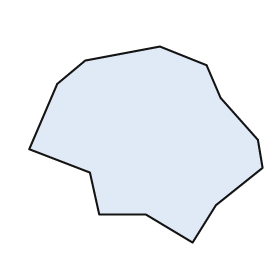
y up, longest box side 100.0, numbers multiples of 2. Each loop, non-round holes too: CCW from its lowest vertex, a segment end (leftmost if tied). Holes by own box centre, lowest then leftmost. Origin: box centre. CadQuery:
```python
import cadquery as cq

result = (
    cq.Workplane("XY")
    .moveTo(20.0, -42.0)
    .lineTo(30.0, -26.0)
    .lineTo(50.0, -10.0)
    .lineTo(48.0, 2.0)
    .lineTo(32.0, 20.0)
    .lineTo(26.0, 34.0)
    .lineTo(6.0, 42.0)
    .lineTo(-26.0, 36.0)
    .lineTo(-38.0, 26.0)
    .lineTo(-50.0, -2.0)
    .lineTo(-24.0, -12.0)
    .lineTo(-20.0, -30.0)
    .lineTo(0.0, -30.0)
    .close()
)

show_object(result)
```